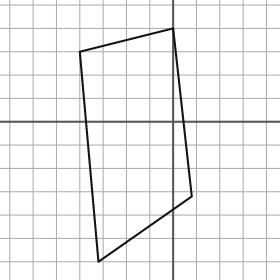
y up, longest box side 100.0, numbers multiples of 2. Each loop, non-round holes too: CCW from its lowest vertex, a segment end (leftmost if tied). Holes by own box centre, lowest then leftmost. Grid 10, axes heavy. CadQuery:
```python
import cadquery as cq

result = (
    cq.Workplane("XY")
    .moveTo(-32.0, -60.0)
    .lineTo(8.0, -32.0)
    .lineTo(0.0, 40.0)
    .lineTo(-40.0, 30.0)
    .close()
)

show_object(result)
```